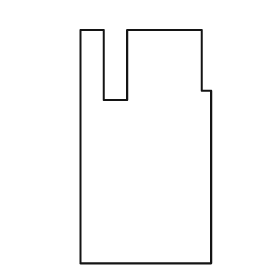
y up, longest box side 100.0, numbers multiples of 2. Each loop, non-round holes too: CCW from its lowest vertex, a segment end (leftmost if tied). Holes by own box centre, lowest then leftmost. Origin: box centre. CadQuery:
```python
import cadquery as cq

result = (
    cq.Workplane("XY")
    .moveTo(-28.0, -50.0)
    .lineTo(28.0, -50.0)
    .lineTo(28.0, 24.0)
    .lineTo(24.0, 24.0)
    .lineTo(24.0, 50.0)
    .lineTo(-8.0, 50.0)
    .lineTo(-8.0, 20.0)
    .lineTo(-18.0, 20.0)
    .lineTo(-18.0, 50.0)
    .lineTo(-28.0, 50.0)
    .close()
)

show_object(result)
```